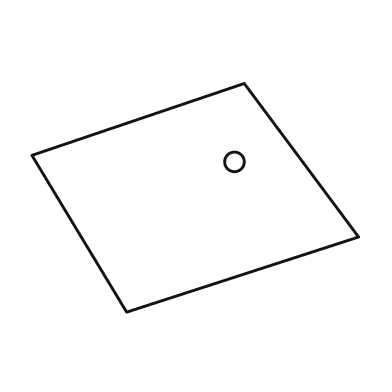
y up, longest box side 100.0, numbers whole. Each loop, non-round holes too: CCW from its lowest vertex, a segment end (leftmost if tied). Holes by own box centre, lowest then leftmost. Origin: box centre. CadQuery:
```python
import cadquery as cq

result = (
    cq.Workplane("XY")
    .moveTo(-21.0, -35.0)
    .lineTo(50.0, -12.0)
    .lineTo(15.0, 35.0)
    .lineTo(-50.0, 13.0)
    .close()
    .moveTo(12.0, 11.0)
    .circle(3.0)
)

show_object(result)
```